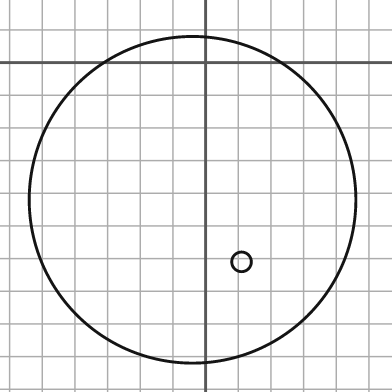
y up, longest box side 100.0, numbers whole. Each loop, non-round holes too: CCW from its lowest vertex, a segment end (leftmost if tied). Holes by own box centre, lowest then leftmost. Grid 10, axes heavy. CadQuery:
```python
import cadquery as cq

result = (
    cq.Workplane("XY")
    .moveTo(-4.0, -42.0)
    .circle(50.0)
    .moveTo(11.0, -61.0)
    .circle(3.0)
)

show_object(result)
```